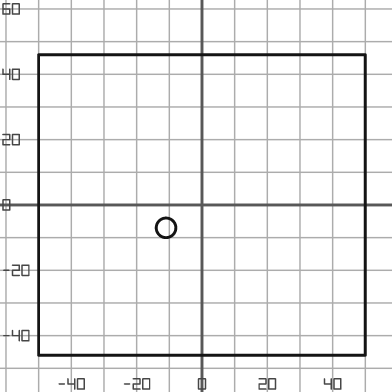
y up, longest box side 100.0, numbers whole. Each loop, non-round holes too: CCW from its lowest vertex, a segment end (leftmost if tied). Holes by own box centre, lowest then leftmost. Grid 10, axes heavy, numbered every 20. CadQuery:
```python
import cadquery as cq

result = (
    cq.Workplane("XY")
    .moveTo(-50.0, -46.0)
    .lineTo(50.0, -46.0)
    .lineTo(50.0, 46.0)
    .lineTo(-50.0, 46.0)
    .close()
    .moveTo(-11.0, -7.0)
    .circle(3.0)
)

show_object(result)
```